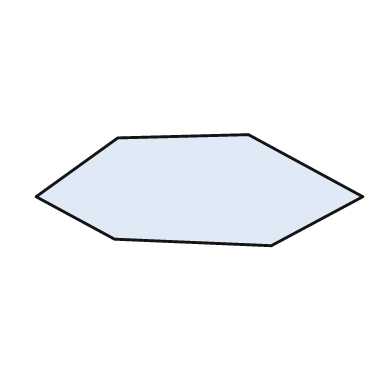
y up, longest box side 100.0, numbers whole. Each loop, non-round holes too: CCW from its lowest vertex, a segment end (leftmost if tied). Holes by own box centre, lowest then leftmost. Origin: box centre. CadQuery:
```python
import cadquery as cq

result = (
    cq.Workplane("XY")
    .moveTo(22.0, -17.0)
    .lineTo(50.0, -2.0)
    .lineTo(15.0, 17.0)
    .lineTo(-25.0, 16.0)
    .lineTo(-50.0, -2.0)
    .lineTo(-26.0, -15.0)
    .close()
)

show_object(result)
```